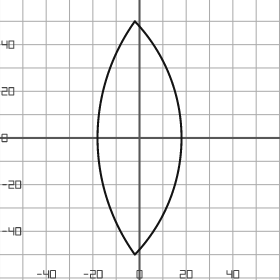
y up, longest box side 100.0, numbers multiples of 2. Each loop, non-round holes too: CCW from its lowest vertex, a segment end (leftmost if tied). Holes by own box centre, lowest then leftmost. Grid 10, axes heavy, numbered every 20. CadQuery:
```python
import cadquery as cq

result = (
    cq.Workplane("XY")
    .moveTo(-2.0, -50.0)
    .threePointArc((18.0, 0.0), (-2.0, 50.0))
    .threePointArc((-18.0, 0.0), (-2.0, -50.0))
    .close()
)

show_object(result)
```